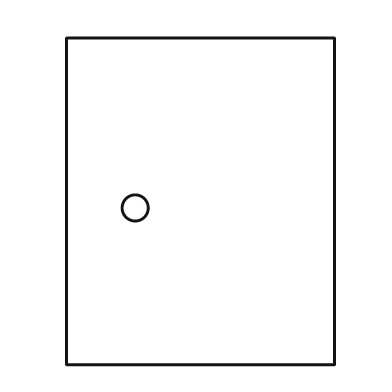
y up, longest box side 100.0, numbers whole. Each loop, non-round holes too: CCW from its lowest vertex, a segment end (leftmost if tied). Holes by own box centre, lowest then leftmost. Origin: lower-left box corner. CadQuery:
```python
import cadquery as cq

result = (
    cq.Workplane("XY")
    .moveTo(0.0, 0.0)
    .lineTo(82.0, 0.0)
    .lineTo(82.0, 100.0)
    .lineTo(0.0, 100.0)
    .close()
    .moveTo(21.0, 48.0)
    .circle(4.0)
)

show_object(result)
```